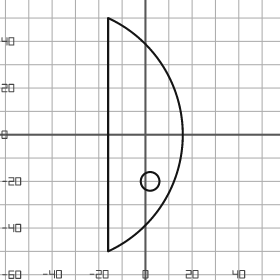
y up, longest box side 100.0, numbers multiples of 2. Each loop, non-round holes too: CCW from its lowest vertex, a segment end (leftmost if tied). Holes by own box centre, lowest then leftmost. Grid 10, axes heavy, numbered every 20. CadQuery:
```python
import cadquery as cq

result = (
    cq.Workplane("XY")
    .moveTo(-16.0, -50.0)
    .threePointArc((16.0, 0.0), (-16.0, 50.0))
    .close()
    .moveTo(2.0, -20.0)
    .circle(4.0)
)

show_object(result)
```